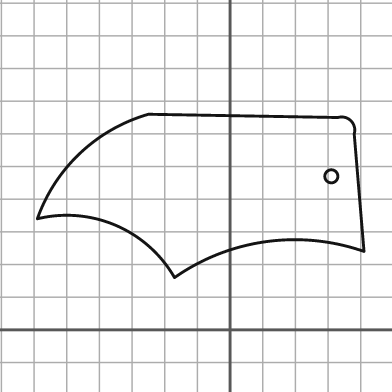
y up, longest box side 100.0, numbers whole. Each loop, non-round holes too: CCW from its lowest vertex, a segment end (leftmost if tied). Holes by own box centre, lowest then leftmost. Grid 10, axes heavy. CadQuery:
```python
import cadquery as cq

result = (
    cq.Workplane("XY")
    .moveTo(-17.0, 16.0)
    .threePointArc((11.0, 27.0), (41.0, 24.0))
    .lineTo(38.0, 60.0)
    .threePointArc((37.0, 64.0), (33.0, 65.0))
    .lineTo(-25.0, 66.0)
    .threePointArc((-46.0, 54.0), (-59.0, 34.0))
    .threePointArc((-35.0, 32.0), (-17.0, 16.0))
    .close()
    .moveTo(31.0, 47.0)
    .circle(2.0)
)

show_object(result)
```